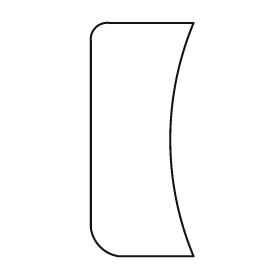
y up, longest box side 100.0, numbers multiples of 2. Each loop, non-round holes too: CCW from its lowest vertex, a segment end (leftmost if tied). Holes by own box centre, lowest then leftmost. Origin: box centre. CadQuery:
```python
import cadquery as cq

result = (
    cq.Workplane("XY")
    .moveTo(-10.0, -50.0)
    .lineTo(22.0, -50.0)
    .threePointArc((12.0, 0.0), (22.0, 50.0))
    .lineTo(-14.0, 50.0)
    .threePointArc((-20.0, 48.0), (-22.0, 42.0))
    .lineTo(-22.0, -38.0)
    .threePointArc((-18.0, -46.0), (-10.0, -50.0))
    .close()
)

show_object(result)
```